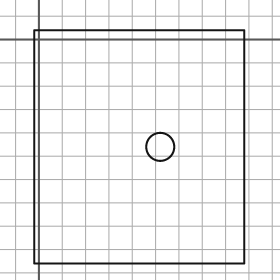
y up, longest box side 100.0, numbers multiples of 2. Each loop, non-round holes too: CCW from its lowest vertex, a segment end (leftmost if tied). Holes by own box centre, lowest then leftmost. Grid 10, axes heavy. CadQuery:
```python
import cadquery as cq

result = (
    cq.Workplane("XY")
    .moveTo(-2.0, -96.0)
    .lineTo(88.0, -96.0)
    .lineTo(88.0, 4.0)
    .lineTo(-2.0, 4.0)
    .close()
    .moveTo(52.0, -46.0)
    .circle(6.0)
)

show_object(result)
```